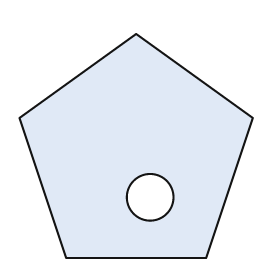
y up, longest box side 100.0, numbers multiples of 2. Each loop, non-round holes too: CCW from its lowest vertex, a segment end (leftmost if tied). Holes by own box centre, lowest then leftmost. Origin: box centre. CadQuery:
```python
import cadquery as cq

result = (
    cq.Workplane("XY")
    .moveTo(-30.0, -48.0)
    .lineTo(30.0, -48.0)
    .lineTo(50.0, 12.0)
    .lineTo(0.0, 48.0)
    .lineTo(-50.0, 12.0)
    .close()
    .moveTo(6.0, -22.0)
    .circle(10.0)
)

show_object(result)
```